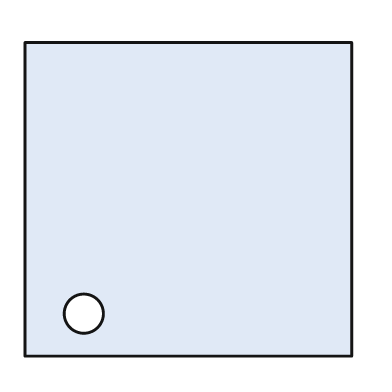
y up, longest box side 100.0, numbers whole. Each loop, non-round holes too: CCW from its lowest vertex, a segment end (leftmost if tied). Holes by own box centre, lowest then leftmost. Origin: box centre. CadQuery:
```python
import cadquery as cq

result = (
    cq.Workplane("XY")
    .moveTo(-50.0, -48.0)
    .lineTo(50.0, -48.0)
    .lineTo(50.0, 48.0)
    .lineTo(-50.0, 48.0)
    .close()
    .moveTo(-32.0, -35.0)
    .circle(6.0)
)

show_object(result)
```